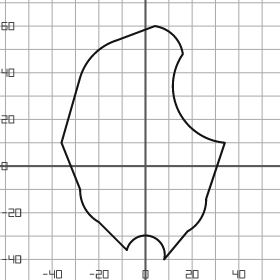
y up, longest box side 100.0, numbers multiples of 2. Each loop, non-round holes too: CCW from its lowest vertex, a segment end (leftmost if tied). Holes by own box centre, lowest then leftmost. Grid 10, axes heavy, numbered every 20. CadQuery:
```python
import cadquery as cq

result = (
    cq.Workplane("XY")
    .moveTo(8.0, -40.0)
    .lineTo(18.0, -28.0)
    .threePointArc((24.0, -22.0), (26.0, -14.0))
    .lineTo(34.0, 10.0)
    .threePointArc((14.0, 24.0), (16.0, 48.0))
    .threePointArc((12.0, 56.0), (4.0, 60.0))
    .lineTo(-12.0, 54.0)
    .threePointArc((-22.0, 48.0), (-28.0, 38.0))
    .lineTo(-36.0, 10.0)
    .lineTo(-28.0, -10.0)
    .threePointArc((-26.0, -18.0), (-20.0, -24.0))
    .lineTo(-8.0, -36.0)
    .threePointArc((2.0, -30.0), (8.0, -40.0))
    .close()
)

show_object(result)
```